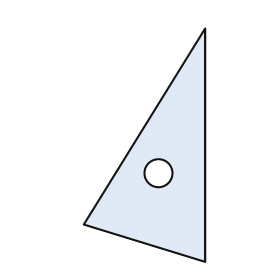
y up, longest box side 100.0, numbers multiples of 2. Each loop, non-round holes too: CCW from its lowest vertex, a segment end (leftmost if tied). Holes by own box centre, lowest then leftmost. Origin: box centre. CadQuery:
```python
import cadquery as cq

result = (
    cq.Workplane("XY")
    .moveTo(26.0, -50.0)
    .lineTo(26.0, 50.0)
    .lineTo(-26.0, -34.0)
    .close()
    .moveTo(6.0, -12.0)
    .circle(6.0)
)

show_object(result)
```